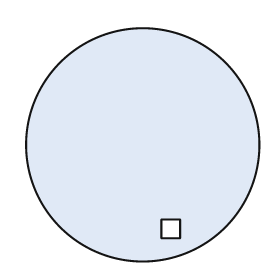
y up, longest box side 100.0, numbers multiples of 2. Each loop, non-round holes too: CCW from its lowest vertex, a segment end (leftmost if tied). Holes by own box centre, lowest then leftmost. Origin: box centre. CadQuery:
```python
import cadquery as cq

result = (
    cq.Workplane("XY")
    .moveTo(0.0, 0.0)
    .circle(50.0)
    .moveTo(8.0, -40.0)
    .lineTo(16.0, -40.0)
    .lineTo(16.0, -32.0)
    .lineTo(8.0, -32.0)
    .close()
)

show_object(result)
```